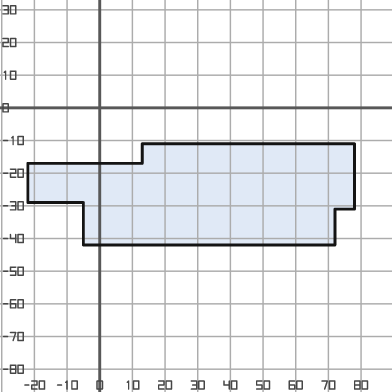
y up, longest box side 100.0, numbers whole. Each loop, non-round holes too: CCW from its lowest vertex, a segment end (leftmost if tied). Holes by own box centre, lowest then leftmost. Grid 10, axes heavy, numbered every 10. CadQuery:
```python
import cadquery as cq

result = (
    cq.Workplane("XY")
    .moveTo(-5.0, -42.0)
    .lineTo(72.0, -42.0)
    .lineTo(72.0, -31.0)
    .lineTo(78.0, -31.0)
    .lineTo(78.0, -11.0)
    .lineTo(13.0, -11.0)
    .lineTo(13.0, -17.0)
    .lineTo(-22.0, -17.0)
    .lineTo(-22.0, -29.0)
    .lineTo(-5.0, -29.0)
    .close()
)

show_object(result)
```